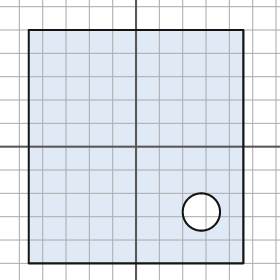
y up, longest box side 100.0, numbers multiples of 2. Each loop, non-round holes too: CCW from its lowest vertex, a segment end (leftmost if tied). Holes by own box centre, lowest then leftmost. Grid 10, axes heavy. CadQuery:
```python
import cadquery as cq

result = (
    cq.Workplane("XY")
    .moveTo(-46.0, -50.0)
    .lineTo(46.0, -50.0)
    .lineTo(46.0, 50.0)
    .lineTo(-46.0, 50.0)
    .close()
    .moveTo(28.0, -28.0)
    .circle(8.0)
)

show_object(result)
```